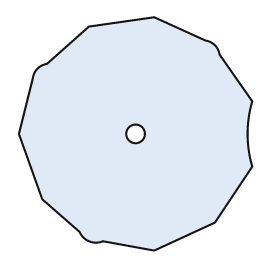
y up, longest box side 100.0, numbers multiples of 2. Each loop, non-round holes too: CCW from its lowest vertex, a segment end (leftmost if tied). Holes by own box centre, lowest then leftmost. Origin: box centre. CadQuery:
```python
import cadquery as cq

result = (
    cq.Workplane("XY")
    .moveTo(8.0, -50.0)
    .lineTo(34.0, -38.0)
    .lineTo(50.0, -14.0)
    .threePointArc((48.0, 0.0), (50.0, 14.0))
    .lineTo(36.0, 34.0)
    .threePointArc((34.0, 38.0), (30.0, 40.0))
    .lineTo(8.0, 50.0)
    .lineTo(-20.0, 46.0)
    .lineTo(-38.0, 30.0)
    .threePointArc((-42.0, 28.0), (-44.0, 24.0))
    .lineTo(-50.0, 0.0)
    .lineTo(-40.0, -28.0)
    .lineTo(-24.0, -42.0)
    .threePointArc((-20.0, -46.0), (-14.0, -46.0))
    .close()
    .moveTo(0.0, 0.0)
    .circle(4.0)
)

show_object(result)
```